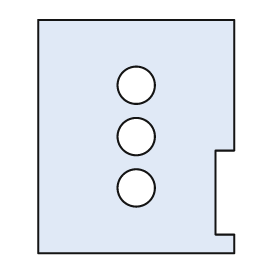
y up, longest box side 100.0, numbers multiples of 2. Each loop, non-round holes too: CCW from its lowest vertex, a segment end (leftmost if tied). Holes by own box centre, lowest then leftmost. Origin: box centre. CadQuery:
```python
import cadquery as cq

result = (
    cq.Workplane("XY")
    .moveTo(-42.0, -50.0)
    .lineTo(42.0, -50.0)
    .lineTo(42.0, -42.0)
    .lineTo(34.0, -42.0)
    .lineTo(34.0, -6.0)
    .lineTo(42.0, -6.0)
    .lineTo(42.0, 50.0)
    .lineTo(-42.0, 50.0)
    .close()
    .moveTo(0.0, -22.0)
    .circle(8.0)
    .moveTo(0.0, 0.0)
    .circle(8.0)
    .moveTo(0.0, 22.0)
    .circle(8.0)
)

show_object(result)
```